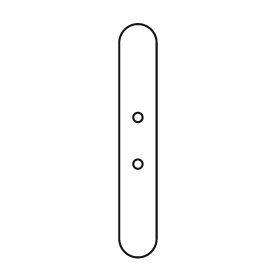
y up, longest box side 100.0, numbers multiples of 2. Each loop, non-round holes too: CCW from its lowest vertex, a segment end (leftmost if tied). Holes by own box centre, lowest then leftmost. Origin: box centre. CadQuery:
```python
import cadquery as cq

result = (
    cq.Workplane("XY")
    .moveTo(-8.0, -42.0)
    .threePointArc((0.0, -50.0), (8.0, -42.0))
    .lineTo(8.0, 42.0)
    .threePointArc((0.0, 50.0), (-8.0, 42.0))
    .close()
    .moveTo(0.0, -10.0)
    .circle(2.0)
    .moveTo(0.0, 10.0)
    .circle(2.0)
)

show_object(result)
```